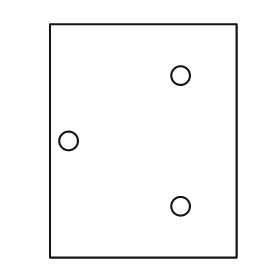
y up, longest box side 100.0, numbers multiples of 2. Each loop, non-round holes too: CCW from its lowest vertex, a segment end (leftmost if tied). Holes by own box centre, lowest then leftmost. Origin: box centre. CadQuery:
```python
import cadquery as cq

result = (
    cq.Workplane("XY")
    .moveTo(-40.0, -50.0)
    .lineTo(40.0, -50.0)
    .lineTo(40.0, 50.0)
    .lineTo(-40.0, 50.0)
    .close()
    .moveTo(16.0, -28.0)
    .circle(4.0)
    .moveTo(-32.0, 0.0)
    .circle(4.0)
    .moveTo(16.0, 28.0)
    .circle(4.0)
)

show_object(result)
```